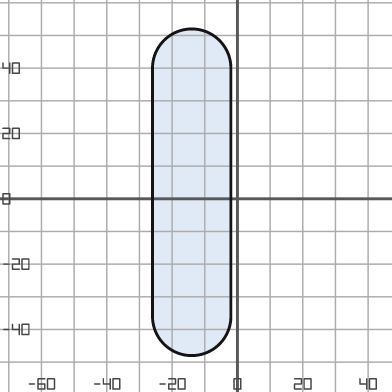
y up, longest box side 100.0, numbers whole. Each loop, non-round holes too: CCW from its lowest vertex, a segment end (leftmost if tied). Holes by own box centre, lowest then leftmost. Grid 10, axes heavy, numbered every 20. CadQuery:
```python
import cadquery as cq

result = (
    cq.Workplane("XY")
    .moveTo(-26.0, -36.0)
    .threePointArc((-14.0, -48.0), (-2.0, -36.0))
    .lineTo(-2.0, 40.0)
    .threePointArc((-14.0, 52.0), (-26.0, 40.0))
    .close()
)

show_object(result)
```